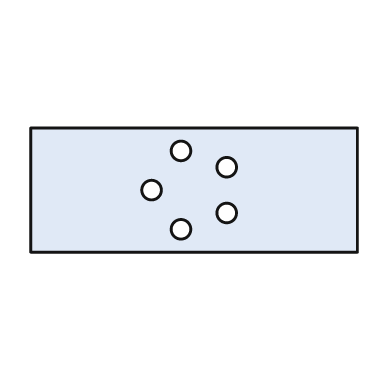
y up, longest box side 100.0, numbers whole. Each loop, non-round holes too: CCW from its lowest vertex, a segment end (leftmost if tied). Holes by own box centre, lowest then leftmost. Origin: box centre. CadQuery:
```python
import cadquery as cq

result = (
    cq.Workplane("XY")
    .moveTo(-50.0, -19.0)
    .lineTo(50.0, -19.0)
    .lineTo(50.0, 19.0)
    .lineTo(-50.0, 19.0)
    .close()
    .moveTo(-4.0, -12.0)
    .circle(3.0)
    .moveTo(10.0, -7.0)
    .circle(3.0)
    .moveTo(-13.0, 0.0)
    .circle(3.0)
    .moveTo(10.0, 7.0)
    .circle(3.0)
    .moveTo(-4.0, 12.0)
    .circle(3.0)
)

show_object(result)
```